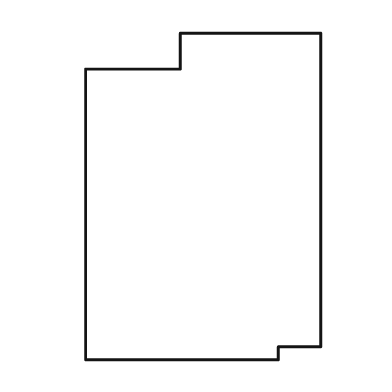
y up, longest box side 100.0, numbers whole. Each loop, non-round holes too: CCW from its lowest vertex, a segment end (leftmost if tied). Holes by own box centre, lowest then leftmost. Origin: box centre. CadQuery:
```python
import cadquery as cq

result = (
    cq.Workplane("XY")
    .moveTo(-36.0, -50.0)
    .lineTo(23.0, -50.0)
    .lineTo(23.0, -46.0)
    .lineTo(36.0, -46.0)
    .lineTo(36.0, 50.0)
    .lineTo(-7.0, 50.0)
    .lineTo(-7.0, 39.0)
    .lineTo(-36.0, 39.0)
    .close()
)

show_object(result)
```